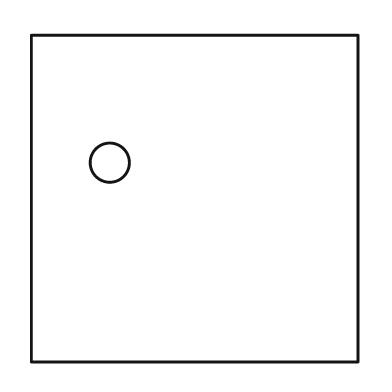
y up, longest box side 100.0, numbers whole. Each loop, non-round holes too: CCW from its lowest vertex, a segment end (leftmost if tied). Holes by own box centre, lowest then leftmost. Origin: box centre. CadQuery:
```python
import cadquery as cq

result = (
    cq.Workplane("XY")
    .moveTo(-50.0, -50.0)
    .lineTo(50.0, -50.0)
    .lineTo(50.0, 50.0)
    .lineTo(-50.0, 50.0)
    .close()
    .moveTo(-26.0, 11.0)
    .circle(6.0)
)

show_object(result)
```